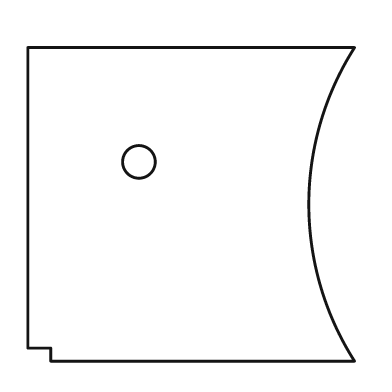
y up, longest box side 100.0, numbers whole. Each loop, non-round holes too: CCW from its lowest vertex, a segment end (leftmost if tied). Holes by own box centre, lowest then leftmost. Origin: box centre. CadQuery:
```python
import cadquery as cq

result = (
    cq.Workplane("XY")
    .moveTo(-43.0, -48.0)
    .lineTo(50.0, -48.0)
    .threePointArc((36.0, 0.0), (50.0, 48.0))
    .lineTo(-50.0, 48.0)
    .lineTo(-50.0, -44.0)
    .lineTo(-43.0, -44.0)
    .close()
    .moveTo(-16.0, 13.0)
    .circle(5.0)
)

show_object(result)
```